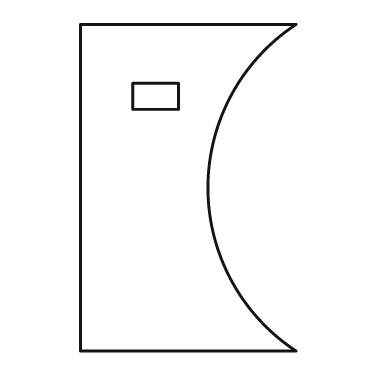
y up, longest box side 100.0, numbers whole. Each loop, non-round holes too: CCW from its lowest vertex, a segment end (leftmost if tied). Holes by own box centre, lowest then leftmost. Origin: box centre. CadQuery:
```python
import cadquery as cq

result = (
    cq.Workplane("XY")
    .moveTo(-33.0, -50.0)
    .lineTo(33.0, -50.0)
    .threePointArc((6.0, 0.0), (33.0, 50.0))
    .lineTo(-33.0, 50.0)
    .close()
    .moveTo(-17.0, 24.0)
    .lineTo(-3.0, 24.0)
    .lineTo(-3.0, 32.0)
    .lineTo(-17.0, 32.0)
    .close()
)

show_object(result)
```